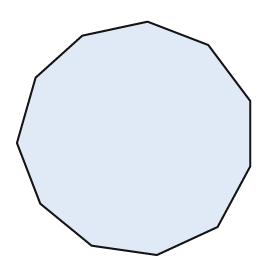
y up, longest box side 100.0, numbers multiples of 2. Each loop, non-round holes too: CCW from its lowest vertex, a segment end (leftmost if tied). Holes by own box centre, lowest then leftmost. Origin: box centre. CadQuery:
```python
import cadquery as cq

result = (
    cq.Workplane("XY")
    .moveTo(10.0, -50.0)
    .lineTo(36.0, -38.0)
    .lineTo(50.0, -12.0)
    .lineTo(50.0, 16.0)
    .lineTo(32.0, 40.0)
    .lineTo(6.0, 50.0)
    .lineTo(-22.0, 44.0)
    .lineTo(-42.0, 26.0)
    .lineTo(-50.0, -2.0)
    .lineTo(-40.0, -28.0)
    .lineTo(-18.0, -46.0)
    .close()
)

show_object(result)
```